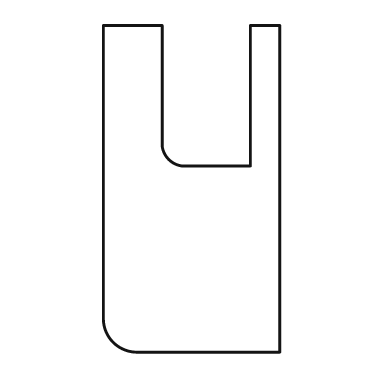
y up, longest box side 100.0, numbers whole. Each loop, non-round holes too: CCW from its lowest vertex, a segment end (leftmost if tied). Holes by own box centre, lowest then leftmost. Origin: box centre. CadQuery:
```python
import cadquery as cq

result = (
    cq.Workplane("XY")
    .moveTo(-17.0, -50.0)
    .lineTo(27.0, -50.0)
    .lineTo(27.0, 50.0)
    .lineTo(18.0, 50.0)
    .lineTo(18.0, 7.0)
    .lineTo(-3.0, 7.0)
    .threePointArc((-7.0, 9.0), (-9.0, 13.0))
    .lineTo(-9.0, 50.0)
    .lineTo(-27.0, 50.0)
    .lineTo(-27.0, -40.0)
    .threePointArc((-24.0, -47.0), (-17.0, -50.0))
    .close()
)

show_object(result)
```